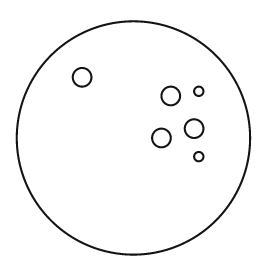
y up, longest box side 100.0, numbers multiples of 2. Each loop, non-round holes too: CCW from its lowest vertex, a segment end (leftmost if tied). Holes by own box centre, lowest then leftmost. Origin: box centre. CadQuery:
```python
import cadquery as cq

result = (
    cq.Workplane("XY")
    .moveTo(0.0, 0.0)
    .circle(50.0)
    .moveTo(28.0, -8.0)
    .circle(2.0)
    .moveTo(12.0, 0.0)
    .circle(4.0)
    .moveTo(26.0, 4.0)
    .circle(4.0)
    .moveTo(16.0, 18.0)
    .circle(4.0)
    .moveTo(28.0, 20.0)
    .circle(2.0)
    .moveTo(-22.0, 26.0)
    .circle(4.0)
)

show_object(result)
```